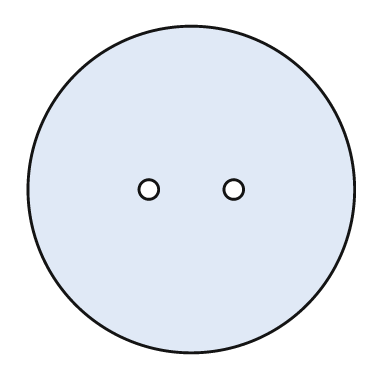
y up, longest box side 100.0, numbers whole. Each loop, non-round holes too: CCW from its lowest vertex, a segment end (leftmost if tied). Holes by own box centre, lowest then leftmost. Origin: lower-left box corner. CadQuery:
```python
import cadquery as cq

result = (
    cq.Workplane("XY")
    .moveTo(50.0, 50.0)
    .circle(50.0)
    .moveTo(37.0, 50.0)
    .circle(3.0)
    .moveTo(63.0, 50.0)
    .circle(3.0)
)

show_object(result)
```